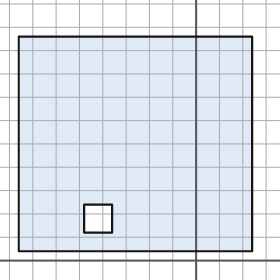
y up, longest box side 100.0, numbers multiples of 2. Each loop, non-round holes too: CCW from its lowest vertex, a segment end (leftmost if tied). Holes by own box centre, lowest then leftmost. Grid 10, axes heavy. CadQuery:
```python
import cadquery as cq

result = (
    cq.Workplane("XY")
    .moveTo(-76.0, 4.0)
    .lineTo(24.0, 4.0)
    .lineTo(24.0, 96.0)
    .lineTo(-76.0, 96.0)
    .close()
    .moveTo(-48.0, 12.0)
    .lineTo(-36.0, 12.0)
    .lineTo(-36.0, 24.0)
    .lineTo(-48.0, 24.0)
    .close()
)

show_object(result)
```